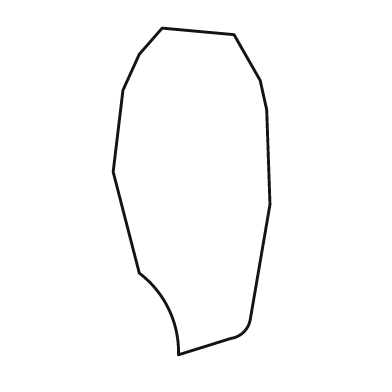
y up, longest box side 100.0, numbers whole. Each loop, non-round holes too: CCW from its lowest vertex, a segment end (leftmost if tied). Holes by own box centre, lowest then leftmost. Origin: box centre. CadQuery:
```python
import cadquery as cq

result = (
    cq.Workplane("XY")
    .moveTo(-4.0, -50.0)
    .lineTo(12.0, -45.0)
    .threePointArc((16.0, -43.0), (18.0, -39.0))
    .lineTo(24.0, -4.0)
    .lineTo(23.0, 25.0)
    .lineTo(21.0, 34.0)
    .lineTo(13.0, 48.0)
    .lineTo(-9.0, 50.0)
    .lineTo(-16.0, 42.0)
    .lineTo(-21.0, 31.0)
    .lineTo(-24.0, 6.0)
    .lineTo(-16.0, -25.0)
    .threePointArc((-7.0, -36.0), (-4.0, -50.0))
    .close()
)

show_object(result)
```